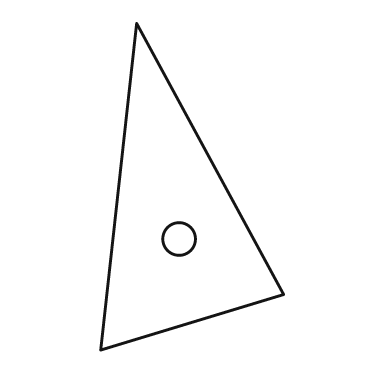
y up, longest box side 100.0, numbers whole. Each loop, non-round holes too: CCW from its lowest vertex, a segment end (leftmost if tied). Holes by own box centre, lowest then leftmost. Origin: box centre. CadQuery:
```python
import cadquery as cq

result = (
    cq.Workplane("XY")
    .moveTo(-28.0, -50.0)
    .lineTo(28.0, -33.0)
    .lineTo(-17.0, 50.0)
    .close()
    .moveTo(-4.0, -16.0)
    .circle(5.0)
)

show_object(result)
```